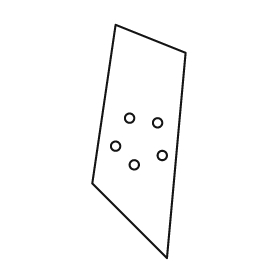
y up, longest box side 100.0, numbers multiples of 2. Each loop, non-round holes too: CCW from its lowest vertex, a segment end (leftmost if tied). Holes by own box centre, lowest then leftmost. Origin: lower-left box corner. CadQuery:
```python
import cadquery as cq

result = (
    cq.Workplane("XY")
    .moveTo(32.0, 0.0)
    .lineTo(40.0, 88.0)
    .lineTo(10.0, 100.0)
    .lineTo(0.0, 32.0)
    .close()
    .moveTo(18.0, 40.0)
    .circle(2.0)
    .moveTo(30.0, 44.0)
    .circle(2.0)
    .moveTo(10.0, 48.0)
    .circle(2.0)
    .moveTo(28.0, 58.0)
    .circle(2.0)
    .moveTo(16.0, 60.0)
    .circle(2.0)
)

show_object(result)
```